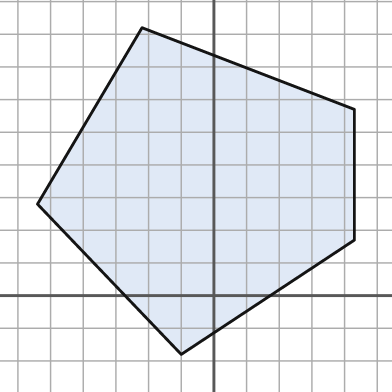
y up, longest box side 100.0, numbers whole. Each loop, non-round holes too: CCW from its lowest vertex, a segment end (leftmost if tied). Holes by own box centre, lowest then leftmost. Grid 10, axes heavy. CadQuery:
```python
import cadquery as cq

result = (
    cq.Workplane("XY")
    .moveTo(-10.0, -18.0)
    .lineTo(43.0, 17.0)
    .lineTo(43.0, 57.0)
    .lineTo(-22.0, 82.0)
    .lineTo(-54.0, 28.0)
    .close()
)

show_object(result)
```